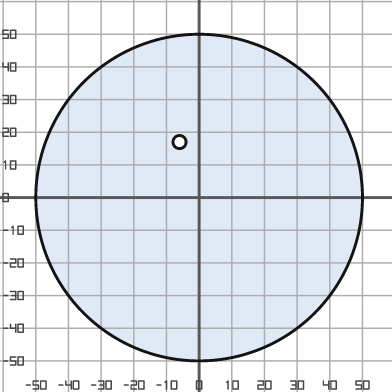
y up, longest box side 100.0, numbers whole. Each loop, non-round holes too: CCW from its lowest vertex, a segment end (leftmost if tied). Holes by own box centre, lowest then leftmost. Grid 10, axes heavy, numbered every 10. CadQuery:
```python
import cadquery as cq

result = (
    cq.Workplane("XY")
    .moveTo(0.0, 0.0)
    .circle(50.0)
    .moveTo(-6.0, 17.0)
    .circle(2.0)
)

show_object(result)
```